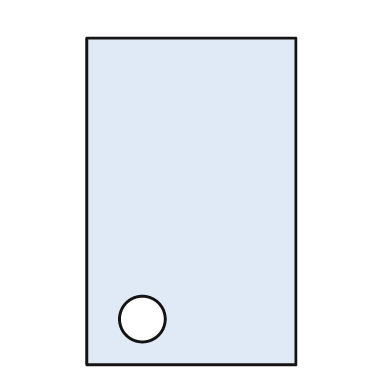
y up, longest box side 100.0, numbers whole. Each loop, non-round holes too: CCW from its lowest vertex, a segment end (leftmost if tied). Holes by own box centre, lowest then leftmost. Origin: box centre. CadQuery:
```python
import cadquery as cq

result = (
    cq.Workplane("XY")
    .moveTo(-32.0, -50.0)
    .lineTo(32.0, -50.0)
    .lineTo(32.0, 50.0)
    .lineTo(-32.0, 50.0)
    .close()
    .moveTo(-15.0, -36.0)
    .circle(7.0)
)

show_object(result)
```